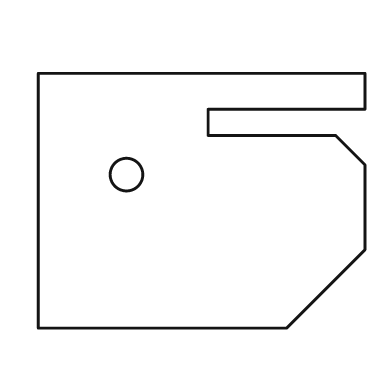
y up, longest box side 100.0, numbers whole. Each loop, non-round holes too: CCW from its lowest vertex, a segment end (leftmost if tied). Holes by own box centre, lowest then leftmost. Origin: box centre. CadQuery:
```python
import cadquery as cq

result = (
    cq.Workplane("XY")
    .moveTo(-50.0, -39.0)
    .lineTo(26.0, -39.0)
    .lineTo(50.0, -15.0)
    .lineTo(50.0, 11.0)
    .lineTo(41.0, 20.0)
    .lineTo(2.0, 20.0)
    .lineTo(2.0, 28.0)
    .lineTo(50.0, 28.0)
    .lineTo(50.0, 39.0)
    .lineTo(-50.0, 39.0)
    .close()
    .moveTo(-23.0, 8.0)
    .circle(5.0)
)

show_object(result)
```